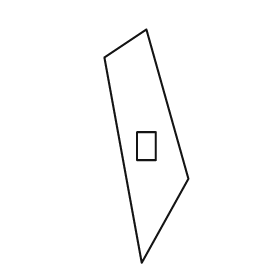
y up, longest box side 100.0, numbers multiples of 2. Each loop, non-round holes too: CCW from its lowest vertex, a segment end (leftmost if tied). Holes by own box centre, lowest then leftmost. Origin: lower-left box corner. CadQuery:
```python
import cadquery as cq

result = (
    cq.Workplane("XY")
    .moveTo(16.0, 0.0)
    .lineTo(36.0, 36.0)
    .lineTo(18.0, 100.0)
    .lineTo(0.0, 88.0)
    .close()
    .moveTo(14.0, 44.0)
    .lineTo(22.0, 44.0)
    .lineTo(22.0, 56.0)
    .lineTo(14.0, 56.0)
    .close()
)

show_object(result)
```